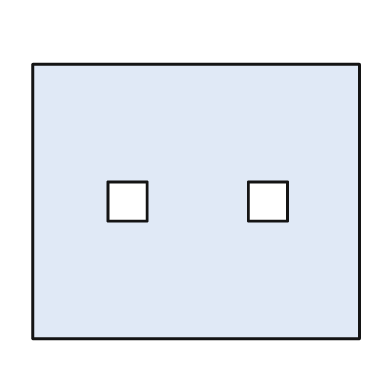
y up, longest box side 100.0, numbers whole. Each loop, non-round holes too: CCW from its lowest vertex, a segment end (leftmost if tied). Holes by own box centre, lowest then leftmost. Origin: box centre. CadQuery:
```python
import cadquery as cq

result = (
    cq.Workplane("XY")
    .moveTo(-50.0, -42.0)
    .lineTo(50.0, -42.0)
    .lineTo(50.0, 42.0)
    .lineTo(-50.0, 42.0)
    .close()
    .moveTo(-27.0, -6.0)
    .lineTo(-15.0, -6.0)
    .lineTo(-15.0, 6.0)
    .lineTo(-27.0, 6.0)
    .close()
    .moveTo(16.0, -6.0)
    .lineTo(28.0, -6.0)
    .lineTo(28.0, 6.0)
    .lineTo(16.0, 6.0)
    .close()
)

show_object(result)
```